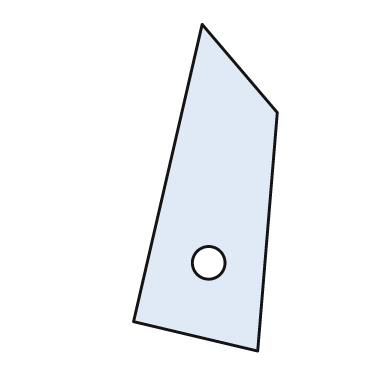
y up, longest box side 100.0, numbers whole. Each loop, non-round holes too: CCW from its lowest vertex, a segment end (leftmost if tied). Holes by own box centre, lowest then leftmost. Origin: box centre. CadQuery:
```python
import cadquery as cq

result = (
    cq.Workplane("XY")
    .moveTo(16.0, -50.0)
    .lineTo(22.0, 23.0)
    .lineTo(-1.0, 50.0)
    .lineTo(-22.0, -41.0)
    .close()
    .moveTo(1.0, -23.0)
    .circle(5.0)
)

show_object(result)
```